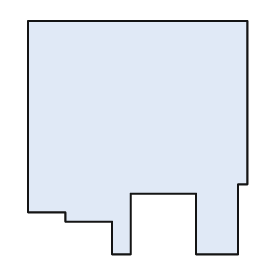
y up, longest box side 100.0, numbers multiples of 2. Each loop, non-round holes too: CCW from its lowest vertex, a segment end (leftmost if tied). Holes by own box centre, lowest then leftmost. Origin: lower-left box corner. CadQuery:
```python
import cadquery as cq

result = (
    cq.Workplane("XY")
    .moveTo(36.0, 0.0)
    .lineTo(44.0, 0.0)
    .lineTo(44.0, 26.0)
    .lineTo(72.0, 26.0)
    .lineTo(72.0, 0.0)
    .lineTo(90.0, 0.0)
    .lineTo(90.0, 30.0)
    .lineTo(94.0, 30.0)
    .lineTo(94.0, 100.0)
    .lineTo(0.0, 100.0)
    .lineTo(0.0, 18.0)
    .lineTo(16.0, 18.0)
    .lineTo(16.0, 14.0)
    .lineTo(36.0, 14.0)
    .close()
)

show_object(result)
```